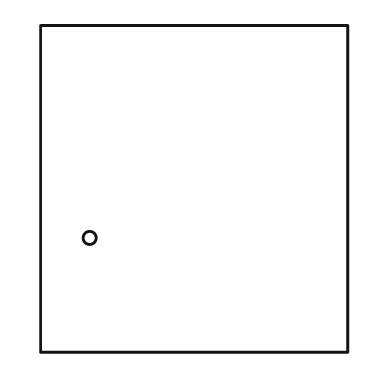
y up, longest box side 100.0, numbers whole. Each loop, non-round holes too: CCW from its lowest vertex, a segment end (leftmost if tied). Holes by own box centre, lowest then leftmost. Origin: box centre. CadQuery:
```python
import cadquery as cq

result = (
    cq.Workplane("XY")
    .moveTo(-47.0, -50.0)
    .lineTo(47.0, -50.0)
    .lineTo(47.0, 50.0)
    .lineTo(-47.0, 50.0)
    .close()
    .moveTo(-32.0, -15.0)
    .circle(2.0)
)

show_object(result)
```